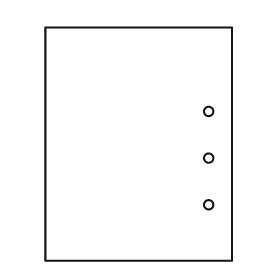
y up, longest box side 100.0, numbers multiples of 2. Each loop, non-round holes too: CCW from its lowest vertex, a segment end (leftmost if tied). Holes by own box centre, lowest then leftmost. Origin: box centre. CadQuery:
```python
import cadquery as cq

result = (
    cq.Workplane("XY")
    .moveTo(-40.0, -50.0)
    .lineTo(40.0, -50.0)
    .lineTo(40.0, 50.0)
    .lineTo(-40.0, 50.0)
    .close()
    .moveTo(30.0, -26.0)
    .circle(2.0)
    .moveTo(30.0, -6.0)
    .circle(2.0)
    .moveTo(30.0, 14.0)
    .circle(2.0)
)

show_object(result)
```